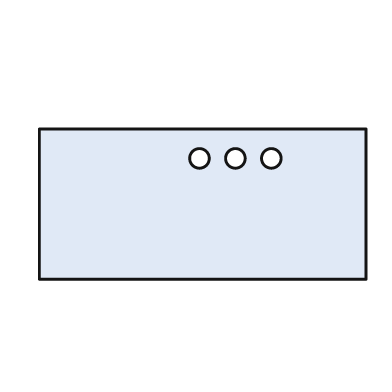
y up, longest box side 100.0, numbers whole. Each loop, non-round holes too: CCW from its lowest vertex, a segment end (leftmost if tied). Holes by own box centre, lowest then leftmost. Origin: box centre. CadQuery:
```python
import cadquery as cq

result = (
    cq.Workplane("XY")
    .moveTo(-50.0, -23.0)
    .lineTo(50.0, -23.0)
    .lineTo(50.0, 23.0)
    .lineTo(-50.0, 23.0)
    .close()
    .moveTo(-1.0, 14.0)
    .circle(3.0)
    .moveTo(10.0, 14.0)
    .circle(3.0)
    .moveTo(21.0, 14.0)
    .circle(3.0)
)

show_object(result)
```